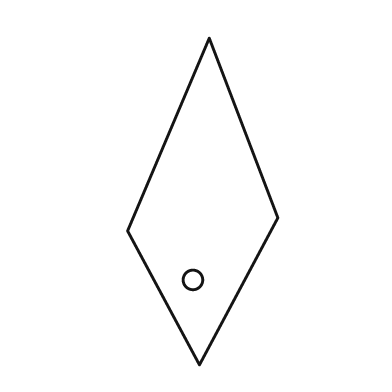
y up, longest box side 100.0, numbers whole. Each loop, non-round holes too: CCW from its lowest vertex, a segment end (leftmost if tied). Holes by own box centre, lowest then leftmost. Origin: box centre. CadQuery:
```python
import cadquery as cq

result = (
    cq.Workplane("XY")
    .moveTo(-1.0, -50.0)
    .lineTo(23.0, -5.0)
    .lineTo(2.0, 50.0)
    .lineTo(-23.0, -9.0)
    .close()
    .moveTo(-3.0, -24.0)
    .circle(3.0)
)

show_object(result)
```